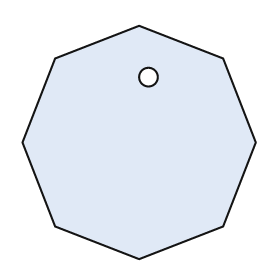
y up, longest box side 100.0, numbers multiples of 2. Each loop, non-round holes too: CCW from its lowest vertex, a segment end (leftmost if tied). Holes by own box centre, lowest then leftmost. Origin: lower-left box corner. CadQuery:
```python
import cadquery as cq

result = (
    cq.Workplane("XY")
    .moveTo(50.0, 0.0)
    .lineTo(86.0, 14.0)
    .lineTo(100.0, 50.0)
    .lineTo(86.0, 86.0)
    .lineTo(50.0, 100.0)
    .lineTo(14.0, 86.0)
    .lineTo(0.0, 50.0)
    .lineTo(14.0, 14.0)
    .close()
    .moveTo(54.0, 78.0)
    .circle(4.0)
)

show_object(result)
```